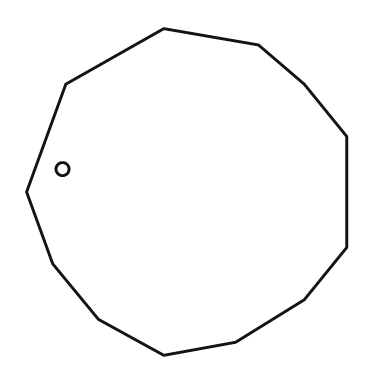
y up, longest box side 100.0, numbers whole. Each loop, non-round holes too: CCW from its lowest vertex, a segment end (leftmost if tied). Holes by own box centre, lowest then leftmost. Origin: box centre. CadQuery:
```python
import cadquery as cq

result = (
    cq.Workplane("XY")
    .moveTo(-7.0, -50.0)
    .lineTo(15.0, -46.0)
    .lineTo(36.0, -33.0)
    .lineTo(49.0, -17.0)
    .lineTo(49.0, 17.0)
    .lineTo(36.0, 33.0)
    .lineTo(22.0, 45.0)
    .lineTo(-7.0, 50.0)
    .lineTo(-37.0, 33.0)
    .lineTo(-49.0, 0.0)
    .lineTo(-41.0, -22.0)
    .lineTo(-27.0, -39.0)
    .close()
    .moveTo(-38.0, 7.0)
    .circle(2.0)
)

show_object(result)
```